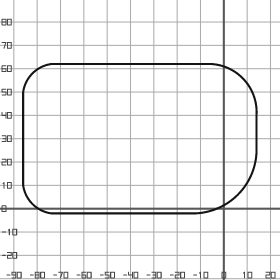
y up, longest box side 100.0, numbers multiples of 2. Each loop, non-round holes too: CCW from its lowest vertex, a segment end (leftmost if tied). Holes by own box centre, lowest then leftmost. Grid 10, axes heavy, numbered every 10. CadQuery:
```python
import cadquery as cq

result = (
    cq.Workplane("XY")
    .moveTo(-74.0, -2.0)
    .lineTo(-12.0, -2.0)
    .threePointArc((6.0, 6.0), (14.0, 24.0))
    .lineTo(14.0, 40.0)
    .threePointArc((8.0, 56.0), (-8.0, 62.0))
    .lineTo(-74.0, 62.0)
    .threePointArc((-82.0, 58.0), (-86.0, 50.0))
    .lineTo(-86.0, 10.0)
    .threePointArc((-82.0, 2.0), (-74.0, -2.0))
    .close()
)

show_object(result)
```